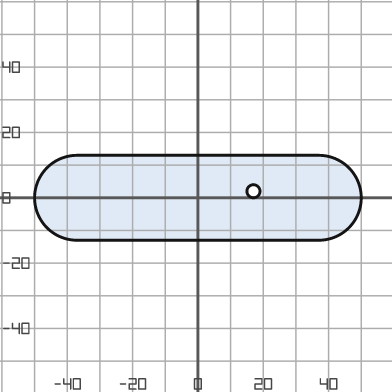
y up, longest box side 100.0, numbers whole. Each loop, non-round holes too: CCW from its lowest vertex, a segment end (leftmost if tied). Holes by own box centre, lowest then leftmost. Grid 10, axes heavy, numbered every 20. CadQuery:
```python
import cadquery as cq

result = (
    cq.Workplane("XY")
    .moveTo(-37.0, -13.0)
    .lineTo(37.0, -13.0)
    .threePointArc((50.0, 0.0), (37.0, 13.0))
    .lineTo(-37.0, 13.0)
    .threePointArc((-50.0, 0.0), (-37.0, -13.0))
    .close()
    .moveTo(17.0, 2.0)
    .circle(2.0)
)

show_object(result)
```